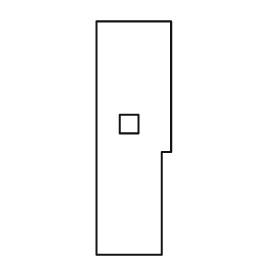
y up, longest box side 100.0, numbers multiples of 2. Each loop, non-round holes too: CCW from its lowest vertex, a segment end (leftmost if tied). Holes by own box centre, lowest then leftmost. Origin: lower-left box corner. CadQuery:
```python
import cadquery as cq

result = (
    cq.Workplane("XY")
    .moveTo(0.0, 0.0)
    .lineTo(28.0, 0.0)
    .lineTo(28.0, 44.0)
    .lineTo(32.0, 44.0)
    .lineTo(32.0, 100.0)
    .lineTo(0.0, 100.0)
    .close()
    .moveTo(10.0, 52.0)
    .lineTo(18.0, 52.0)
    .lineTo(18.0, 60.0)
    .lineTo(10.0, 60.0)
    .close()
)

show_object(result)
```